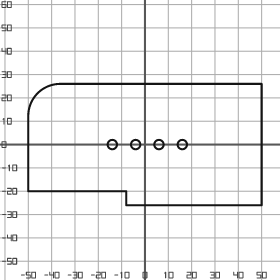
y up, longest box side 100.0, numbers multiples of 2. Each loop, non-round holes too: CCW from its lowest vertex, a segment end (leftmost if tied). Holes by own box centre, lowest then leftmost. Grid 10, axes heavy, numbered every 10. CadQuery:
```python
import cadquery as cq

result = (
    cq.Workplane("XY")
    .moveTo(-8.0, -26.0)
    .lineTo(50.0, -26.0)
    .lineTo(50.0, 26.0)
    .lineTo(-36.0, 26.0)
    .threePointArc((-46.0, 22.0), (-50.0, 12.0))
    .lineTo(-50.0, -20.0)
    .lineTo(-8.0, -20.0)
    .close()
    .moveTo(-14.0, 0.0)
    .circle(2.0)
    .moveTo(-4.0, 0.0)
    .circle(2.0)
    .moveTo(6.0, 0.0)
    .circle(2.0)
    .moveTo(16.0, 0.0)
    .circle(2.0)
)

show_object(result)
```